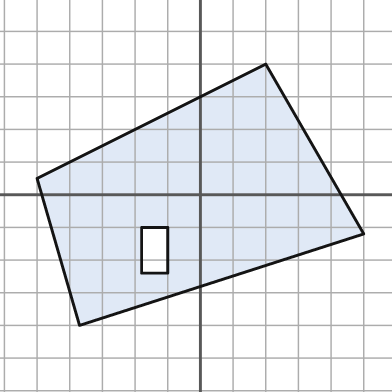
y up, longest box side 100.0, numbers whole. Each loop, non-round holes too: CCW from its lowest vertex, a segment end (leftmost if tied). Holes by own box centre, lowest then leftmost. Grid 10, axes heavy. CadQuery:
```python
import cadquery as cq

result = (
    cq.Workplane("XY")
    .moveTo(-37.0, -40.0)
    .lineTo(50.0, -12.0)
    .lineTo(20.0, 40.0)
    .lineTo(-50.0, 5.0)
    .close()
    .moveTo(-18.0, -24.0)
    .lineTo(-10.0, -24.0)
    .lineTo(-10.0, -10.0)
    .lineTo(-18.0, -10.0)
    .close()
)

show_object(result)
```